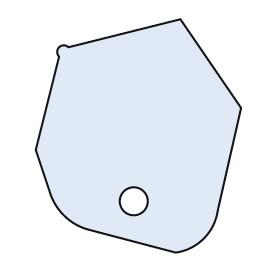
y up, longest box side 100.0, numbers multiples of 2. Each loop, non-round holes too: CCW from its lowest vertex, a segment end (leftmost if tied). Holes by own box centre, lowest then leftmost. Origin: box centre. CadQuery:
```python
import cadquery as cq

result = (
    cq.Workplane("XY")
    .moveTo(16.0, -50.0)
    .threePointArc((28.0, -44.0), (34.0, -32.0))
    .lineTo(44.0, 12.0)
    .lineTo(18.0, 50.0)
    .lineTo(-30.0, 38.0)
    .threePointArc((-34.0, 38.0), (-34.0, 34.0))
    .lineTo(-44.0, -6.0)
    .lineTo(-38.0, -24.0)
    .threePointArc((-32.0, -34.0), (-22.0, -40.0))
    .close()
    .moveTo(-2.0, -28.0)
    .circle(6.0)
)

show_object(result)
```